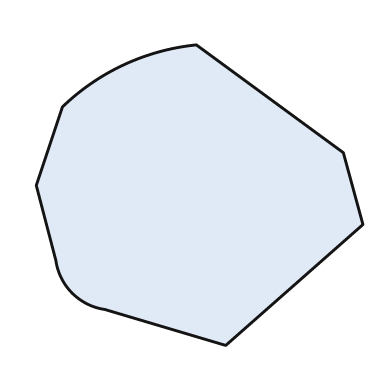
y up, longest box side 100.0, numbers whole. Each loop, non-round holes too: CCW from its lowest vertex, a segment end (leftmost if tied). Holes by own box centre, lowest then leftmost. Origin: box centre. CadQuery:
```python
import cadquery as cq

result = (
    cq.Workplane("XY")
    .moveTo(8.0, -46.0)
    .lineTo(50.0, -9.0)
    .lineTo(44.0, 13.0)
    .lineTo(-1.0, 46.0)
    .threePointArc((-23.0, 40.0), (-42.0, 27.0))
    .lineTo(-50.0, 3.0)
    .lineTo(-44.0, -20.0)
    .threePointArc((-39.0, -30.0), (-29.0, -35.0))
    .close()
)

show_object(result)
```